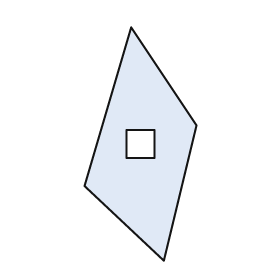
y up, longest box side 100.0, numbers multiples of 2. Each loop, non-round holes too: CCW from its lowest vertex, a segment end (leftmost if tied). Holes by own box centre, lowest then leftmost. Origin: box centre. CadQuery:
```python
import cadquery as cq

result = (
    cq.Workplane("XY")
    .moveTo(10.0, -50.0)
    .lineTo(24.0, 8.0)
    .lineTo(-4.0, 50.0)
    .lineTo(-24.0, -18.0)
    .close()
    .moveTo(-6.0, -6.0)
    .lineTo(6.0, -6.0)
    .lineTo(6.0, 6.0)
    .lineTo(-6.0, 6.0)
    .close()
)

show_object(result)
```